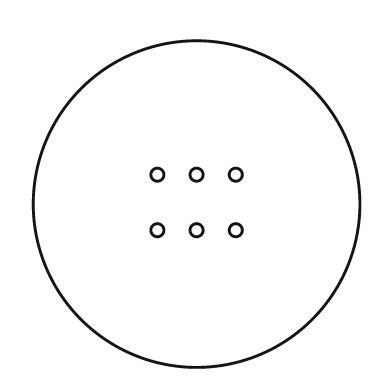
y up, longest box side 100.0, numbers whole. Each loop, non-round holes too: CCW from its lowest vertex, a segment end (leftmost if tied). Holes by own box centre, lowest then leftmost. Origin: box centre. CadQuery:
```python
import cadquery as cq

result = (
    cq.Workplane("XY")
    .moveTo(0.0, 0.0)
    .circle(50.0)
    .moveTo(-12.0, -8.0)
    .circle(2.0)
    .moveTo(0.0, -8.0)
    .circle(2.0)
    .moveTo(12.0, -8.0)
    .circle(2.0)
    .moveTo(-12.0, 9.0)
    .circle(2.0)
    .moveTo(0.0, 9.0)
    .circle(2.0)
    .moveTo(12.0, 9.0)
    .circle(2.0)
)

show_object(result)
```